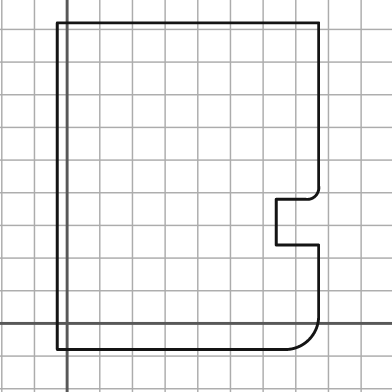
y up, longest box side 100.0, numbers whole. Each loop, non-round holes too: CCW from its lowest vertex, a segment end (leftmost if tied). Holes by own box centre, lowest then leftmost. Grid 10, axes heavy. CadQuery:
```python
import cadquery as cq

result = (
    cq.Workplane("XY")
    .moveTo(-3.0, -8.0)
    .lineTo(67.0, -8.0)
    .threePointArc((74.0, -5.0), (77.0, 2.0))
    .lineTo(77.0, 24.0)
    .lineTo(64.0, 24.0)
    .lineTo(64.0, 38.0)
    .lineTo(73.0, 38.0)
    .threePointArc((76.0, 39.0), (77.0, 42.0))
    .lineTo(77.0, 92.0)
    .lineTo(-3.0, 92.0)
    .close()
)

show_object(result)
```